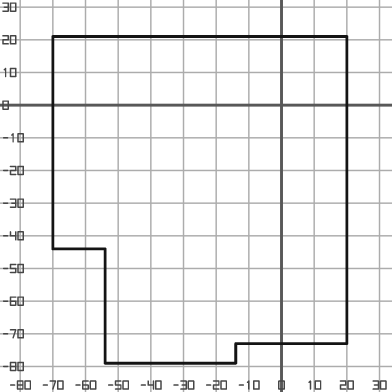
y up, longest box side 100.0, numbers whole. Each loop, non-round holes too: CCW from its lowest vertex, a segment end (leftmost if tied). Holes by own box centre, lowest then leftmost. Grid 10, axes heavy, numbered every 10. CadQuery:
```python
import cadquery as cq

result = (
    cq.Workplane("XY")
    .moveTo(-54.0, -79.0)
    .lineTo(-14.0, -79.0)
    .lineTo(-14.0, -73.0)
    .lineTo(20.0, -73.0)
    .lineTo(20.0, 21.0)
    .lineTo(-70.0, 21.0)
    .lineTo(-70.0, -44.0)
    .lineTo(-54.0, -44.0)
    .close()
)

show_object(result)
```